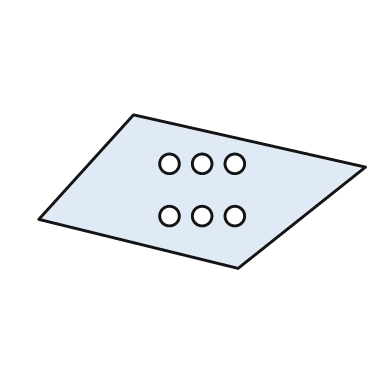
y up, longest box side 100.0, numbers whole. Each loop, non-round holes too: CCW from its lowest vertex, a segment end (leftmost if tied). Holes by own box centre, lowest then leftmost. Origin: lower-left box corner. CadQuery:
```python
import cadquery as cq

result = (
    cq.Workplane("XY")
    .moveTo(61.0, 0.0)
    .lineTo(100.0, 31.0)
    .lineTo(29.0, 47.0)
    .lineTo(0.0, 15.0)
    .close()
    .moveTo(40.0, 16.0)
    .circle(3.0)
    .moveTo(50.0, 16.0)
    .circle(3.0)
    .moveTo(60.0, 16.0)
    .circle(3.0)
    .moveTo(40.0, 32.0)
    .circle(3.0)
    .moveTo(50.0, 32.0)
    .circle(3.0)
    .moveTo(60.0, 32.0)
    .circle(3.0)
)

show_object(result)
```